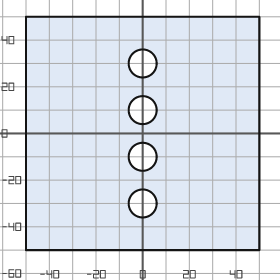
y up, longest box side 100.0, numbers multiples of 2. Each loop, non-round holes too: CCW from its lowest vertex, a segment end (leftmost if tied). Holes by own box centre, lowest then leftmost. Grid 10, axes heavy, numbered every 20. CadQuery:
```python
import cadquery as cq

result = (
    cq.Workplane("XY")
    .moveTo(-50.0, -50.0)
    .lineTo(50.0, -50.0)
    .lineTo(50.0, 50.0)
    .lineTo(-50.0, 50.0)
    .close()
    .moveTo(0.0, -30.0)
    .circle(6.0)
    .moveTo(0.0, -10.0)
    .circle(6.0)
    .moveTo(0.0, 10.0)
    .circle(6.0)
    .moveTo(0.0, 30.0)
    .circle(6.0)
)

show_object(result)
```